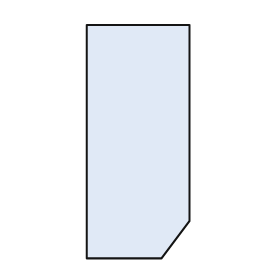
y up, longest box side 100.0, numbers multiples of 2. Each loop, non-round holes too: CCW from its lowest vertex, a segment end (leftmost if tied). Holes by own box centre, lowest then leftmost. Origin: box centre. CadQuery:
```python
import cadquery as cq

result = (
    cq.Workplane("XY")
    .moveTo(-22.0, -50.0)
    .lineTo(10.0, -50.0)
    .lineTo(22.0, -34.0)
    .lineTo(22.0, 50.0)
    .lineTo(-22.0, 50.0)
    .close()
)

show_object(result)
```